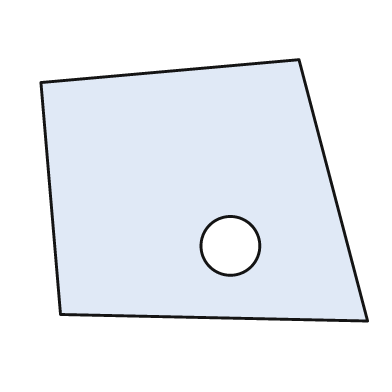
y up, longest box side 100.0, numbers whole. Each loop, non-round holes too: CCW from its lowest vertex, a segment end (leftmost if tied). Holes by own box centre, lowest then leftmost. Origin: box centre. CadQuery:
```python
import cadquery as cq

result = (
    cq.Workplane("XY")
    .moveTo(50.0, -40.0)
    .lineTo(29.0, 40.0)
    .lineTo(-50.0, 33.0)
    .lineTo(-44.0, -38.0)
    .close()
    .moveTo(8.0, -17.0)
    .circle(9.0)
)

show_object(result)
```